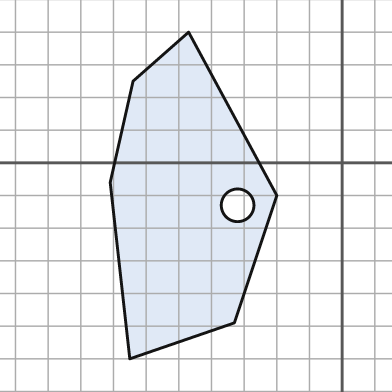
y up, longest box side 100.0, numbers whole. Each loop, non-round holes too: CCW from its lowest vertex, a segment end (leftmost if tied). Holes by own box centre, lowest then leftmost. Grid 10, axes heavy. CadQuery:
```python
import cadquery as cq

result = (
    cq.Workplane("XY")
    .moveTo(-65.0, -60.0)
    .lineTo(-33.0, -49.0)
    .lineTo(-20.0, -10.0)
    .lineTo(-47.0, 40.0)
    .lineTo(-64.0, 25.0)
    .lineTo(-71.0, -6.0)
    .close()
    .moveTo(-32.0, -13.0)
    .circle(5.0)
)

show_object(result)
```